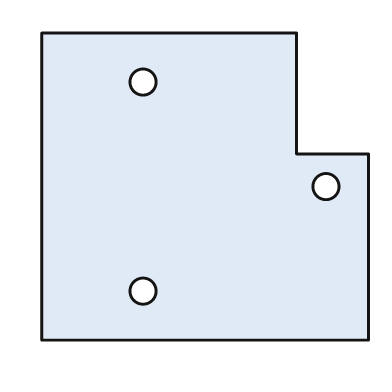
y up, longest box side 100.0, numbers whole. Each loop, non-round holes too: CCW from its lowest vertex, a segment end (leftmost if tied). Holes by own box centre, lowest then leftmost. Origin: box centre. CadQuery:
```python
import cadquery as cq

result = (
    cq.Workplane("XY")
    .moveTo(-50.0, -47.0)
    .lineTo(50.0, -47.0)
    .lineTo(50.0, 10.0)
    .lineTo(28.0, 10.0)
    .lineTo(28.0, 47.0)
    .lineTo(-50.0, 47.0)
    .close()
    .moveTo(-19.0, -32.0)
    .circle(4.0)
    .moveTo(37.0, 0.0)
    .circle(4.0)
    .moveTo(-19.0, 32.0)
    .circle(4.0)
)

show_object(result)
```